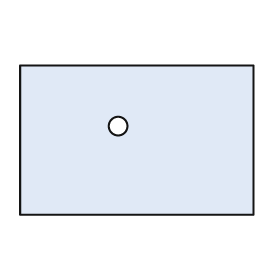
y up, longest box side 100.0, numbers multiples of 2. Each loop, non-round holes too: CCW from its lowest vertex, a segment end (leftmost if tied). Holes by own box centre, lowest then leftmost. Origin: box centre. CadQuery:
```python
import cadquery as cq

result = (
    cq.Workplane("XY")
    .moveTo(-50.0, -32.0)
    .lineTo(50.0, -32.0)
    .lineTo(50.0, 32.0)
    .lineTo(-50.0, 32.0)
    .close()
    .moveTo(-8.0, 6.0)
    .circle(4.0)
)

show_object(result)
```